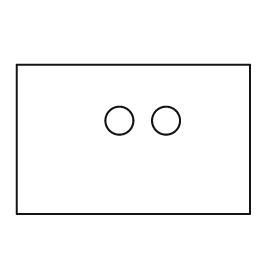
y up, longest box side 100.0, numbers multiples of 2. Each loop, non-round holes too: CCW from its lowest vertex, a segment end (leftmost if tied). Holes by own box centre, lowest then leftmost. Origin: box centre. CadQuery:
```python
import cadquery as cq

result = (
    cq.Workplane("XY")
    .moveTo(-50.0, -32.0)
    .lineTo(50.0, -32.0)
    .lineTo(50.0, 32.0)
    .lineTo(-50.0, 32.0)
    .close()
    .moveTo(-6.0, 8.0)
    .circle(6.0)
    .moveTo(14.0, 8.0)
    .circle(6.0)
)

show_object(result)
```